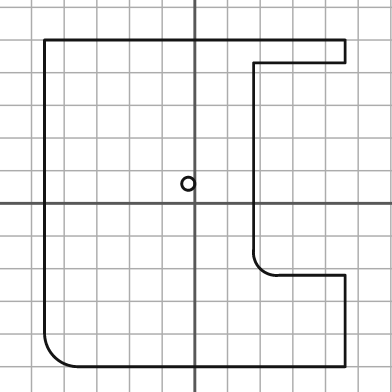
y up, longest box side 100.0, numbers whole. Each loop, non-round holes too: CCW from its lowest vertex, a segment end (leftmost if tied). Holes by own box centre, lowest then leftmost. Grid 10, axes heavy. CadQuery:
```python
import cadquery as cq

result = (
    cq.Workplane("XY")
    .moveTo(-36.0, -50.0)
    .lineTo(46.0, -50.0)
    .lineTo(46.0, -22.0)
    .lineTo(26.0, -22.0)
    .threePointArc((20.0, -20.0), (18.0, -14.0))
    .lineTo(18.0, 43.0)
    .lineTo(46.0, 43.0)
    .lineTo(46.0, 50.0)
    .lineTo(-46.0, 50.0)
    .lineTo(-46.0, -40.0)
    .threePointArc((-43.0, -47.0), (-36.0, -50.0))
    .close()
    .moveTo(-2.0, 6.0)
    .circle(2.0)
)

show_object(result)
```